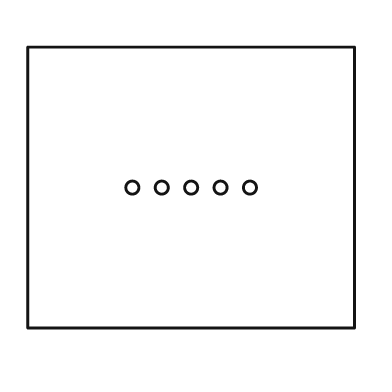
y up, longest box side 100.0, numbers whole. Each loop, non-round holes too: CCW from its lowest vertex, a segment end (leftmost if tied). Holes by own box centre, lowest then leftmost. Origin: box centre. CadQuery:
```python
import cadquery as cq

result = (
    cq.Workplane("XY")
    .moveTo(-50.0, -43.0)
    .lineTo(50.0, -43.0)
    .lineTo(50.0, 43.0)
    .lineTo(-50.0, 43.0)
    .close()
    .moveTo(-18.0, 0.0)
    .circle(2.0)
    .moveTo(-9.0, 0.0)
    .circle(2.0)
    .moveTo(0.0, 0.0)
    .circle(2.0)
    .moveTo(9.0, 0.0)
    .circle(2.0)
    .moveTo(18.0, 0.0)
    .circle(2.0)
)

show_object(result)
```